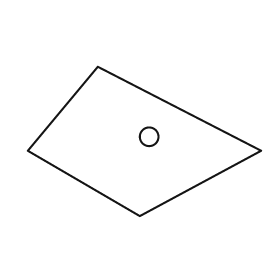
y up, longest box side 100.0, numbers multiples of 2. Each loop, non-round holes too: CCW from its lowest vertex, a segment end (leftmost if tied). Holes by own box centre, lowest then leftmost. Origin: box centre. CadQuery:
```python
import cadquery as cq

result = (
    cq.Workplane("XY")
    .moveTo(-2.0, -32.0)
    .lineTo(50.0, -4.0)
    .lineTo(-20.0, 32.0)
    .lineTo(-50.0, -4.0)
    .close()
    .moveTo(2.0, 2.0)
    .circle(4.0)
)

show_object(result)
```